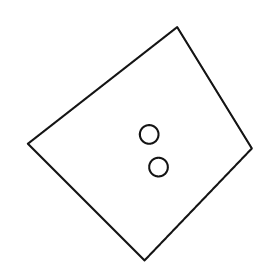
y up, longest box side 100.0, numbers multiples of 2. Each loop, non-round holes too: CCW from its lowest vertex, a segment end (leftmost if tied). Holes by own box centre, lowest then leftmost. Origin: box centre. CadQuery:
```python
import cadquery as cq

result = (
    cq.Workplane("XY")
    .moveTo(2.0, -50.0)
    .lineTo(48.0, -2.0)
    .lineTo(16.0, 50.0)
    .lineTo(-48.0, 0.0)
    .close()
    .moveTo(8.0, -10.0)
    .circle(4.0)
    .moveTo(4.0, 4.0)
    .circle(4.0)
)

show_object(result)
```